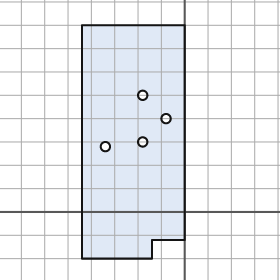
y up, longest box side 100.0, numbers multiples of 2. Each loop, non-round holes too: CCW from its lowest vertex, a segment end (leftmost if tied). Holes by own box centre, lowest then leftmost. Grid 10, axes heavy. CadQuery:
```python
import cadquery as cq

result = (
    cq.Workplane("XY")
    .moveTo(-44.0, -20.0)
    .lineTo(-14.0, -20.0)
    .lineTo(-14.0, -12.0)
    .lineTo(0.0, -12.0)
    .lineTo(0.0, 80.0)
    .lineTo(-44.0, 80.0)
    .close()
    .moveTo(-34.0, 28.0)
    .circle(2.0)
    .moveTo(-18.0, 30.0)
    .circle(2.0)
    .moveTo(-8.0, 40.0)
    .circle(2.0)
    .moveTo(-18.0, 50.0)
    .circle(2.0)
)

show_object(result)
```